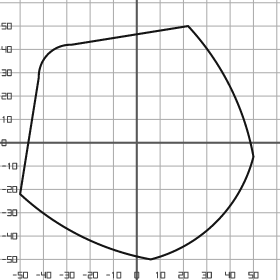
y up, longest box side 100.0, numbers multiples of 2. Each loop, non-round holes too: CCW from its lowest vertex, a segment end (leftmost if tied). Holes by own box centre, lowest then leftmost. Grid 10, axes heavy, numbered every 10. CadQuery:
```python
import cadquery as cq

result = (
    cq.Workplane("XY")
    .moveTo(6.0, -50.0)
    .threePointArc((34.0, -34.0), (50.0, -6.0))
    .threePointArc((40.0, 24.0), (22.0, 50.0))
    .lineTo(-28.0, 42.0)
    .threePointArc((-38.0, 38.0), (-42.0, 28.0))
    .lineTo(-50.0, -22.0)
    .threePointArc((-24.0, -40.0), (6.0, -50.0))
    .close()
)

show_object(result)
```